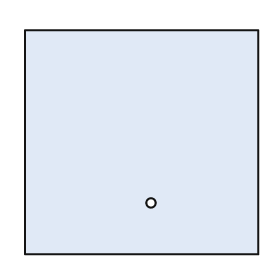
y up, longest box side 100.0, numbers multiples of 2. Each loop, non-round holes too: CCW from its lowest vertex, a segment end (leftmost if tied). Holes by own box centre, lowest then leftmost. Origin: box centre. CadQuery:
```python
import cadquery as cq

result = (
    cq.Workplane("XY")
    .moveTo(-50.0, -48.0)
    .lineTo(50.0, -48.0)
    .lineTo(50.0, 48.0)
    .lineTo(-50.0, 48.0)
    .close()
    .moveTo(4.0, -26.0)
    .circle(2.0)
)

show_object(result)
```